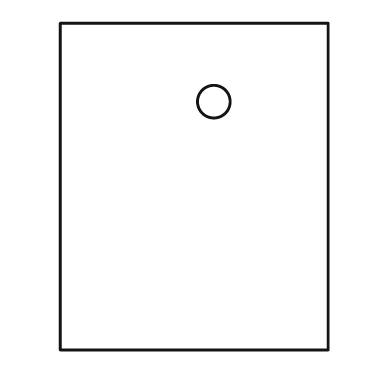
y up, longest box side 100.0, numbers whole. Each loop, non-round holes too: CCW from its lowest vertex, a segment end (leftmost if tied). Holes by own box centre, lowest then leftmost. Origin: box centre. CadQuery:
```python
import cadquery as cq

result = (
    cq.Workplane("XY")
    .moveTo(-41.0, -50.0)
    .lineTo(41.0, -50.0)
    .lineTo(41.0, 50.0)
    .lineTo(-41.0, 50.0)
    .close()
    .moveTo(6.0, 26.0)
    .circle(5.0)
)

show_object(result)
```